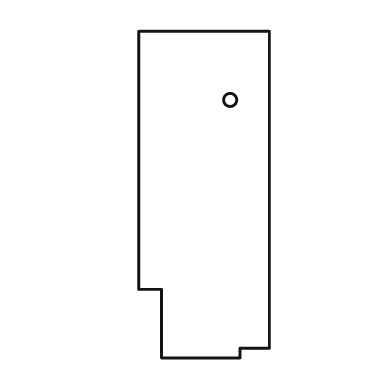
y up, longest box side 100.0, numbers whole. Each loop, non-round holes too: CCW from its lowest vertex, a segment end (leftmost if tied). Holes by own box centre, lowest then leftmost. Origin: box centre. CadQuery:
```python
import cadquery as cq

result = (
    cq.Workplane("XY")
    .moveTo(-13.0, -50.0)
    .lineTo(11.0, -50.0)
    .lineTo(11.0, -47.0)
    .lineTo(20.0, -47.0)
    .lineTo(20.0, 50.0)
    .lineTo(-20.0, 50.0)
    .lineTo(-20.0, -29.0)
    .lineTo(-13.0, -29.0)
    .close()
    .moveTo(8.0, 29.0)
    .circle(2.0)
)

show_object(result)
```